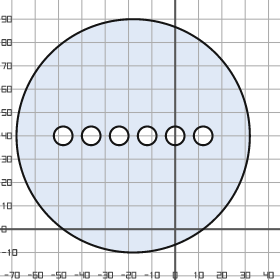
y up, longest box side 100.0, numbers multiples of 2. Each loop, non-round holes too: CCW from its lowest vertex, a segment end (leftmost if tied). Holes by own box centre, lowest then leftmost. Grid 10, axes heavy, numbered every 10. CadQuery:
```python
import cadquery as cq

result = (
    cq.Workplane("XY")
    .moveTo(-18.0, 40.0)
    .circle(50.0)
    .moveTo(-48.0, 40.0)
    .circle(4.0)
    .moveTo(-36.0, 40.0)
    .circle(4.0)
    .moveTo(-24.0, 40.0)
    .circle(4.0)
    .moveTo(-12.0, 40.0)
    .circle(4.0)
    .moveTo(0.0, 40.0)
    .circle(4.0)
    .moveTo(12.0, 40.0)
    .circle(4.0)
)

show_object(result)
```